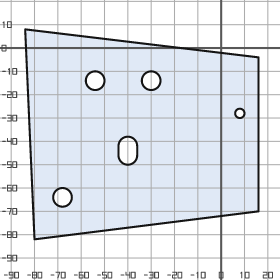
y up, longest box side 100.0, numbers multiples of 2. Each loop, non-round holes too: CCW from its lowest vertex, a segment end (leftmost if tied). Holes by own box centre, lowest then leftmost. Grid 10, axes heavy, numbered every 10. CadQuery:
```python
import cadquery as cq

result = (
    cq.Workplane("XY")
    .moveTo(-80.0, -82.0)
    .lineTo(16.0, -70.0)
    .lineTo(16.0, -4.0)
    .lineTo(-84.0, 8.0)
    .close()
    .moveTo(-68.0, -64.0)
    .circle(4.0)
    .moveTo(-44.0, -46.0)
    .threePointArc((-40.0, -50.0), (-36.0, -46.0))
    .lineTo(-36.0, -42.0)
    .threePointArc((-40.0, -38.0), (-44.0, -42.0))
    .close()
    .moveTo(8.0, -28.0)
    .circle(2.0)
    .moveTo(-54.0, -14.0)
    .circle(4.0)
    .moveTo(-30.0, -14.0)
    .circle(4.0)
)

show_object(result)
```